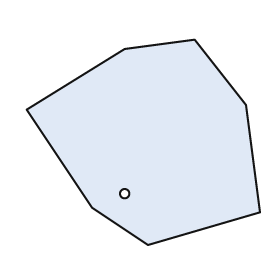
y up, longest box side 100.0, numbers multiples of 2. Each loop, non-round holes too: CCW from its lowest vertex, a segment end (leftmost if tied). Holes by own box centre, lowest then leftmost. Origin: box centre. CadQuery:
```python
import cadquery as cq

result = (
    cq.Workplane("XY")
    .moveTo(2.0, -44.0)
    .lineTo(50.0, -30.0)
    .lineTo(44.0, 16.0)
    .lineTo(22.0, 44.0)
    .lineTo(-8.0, 40.0)
    .lineTo(-50.0, 14.0)
    .lineTo(-22.0, -28.0)
    .close()
    .moveTo(-8.0, -22.0)
    .circle(2.0)
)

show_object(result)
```